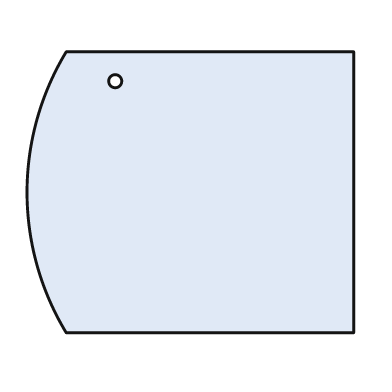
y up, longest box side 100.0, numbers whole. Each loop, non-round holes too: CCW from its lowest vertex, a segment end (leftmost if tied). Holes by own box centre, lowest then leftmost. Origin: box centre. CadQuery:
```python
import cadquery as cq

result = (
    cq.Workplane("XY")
    .moveTo(-38.0, -43.0)
    .lineTo(50.0, -43.0)
    .lineTo(50.0, 43.0)
    .lineTo(-38.0, 43.0)
    .threePointArc((-50.0, 0.0), (-38.0, -43.0))
    .close()
    .moveTo(-23.0, 34.0)
    .circle(2.0)
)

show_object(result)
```